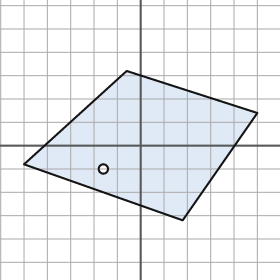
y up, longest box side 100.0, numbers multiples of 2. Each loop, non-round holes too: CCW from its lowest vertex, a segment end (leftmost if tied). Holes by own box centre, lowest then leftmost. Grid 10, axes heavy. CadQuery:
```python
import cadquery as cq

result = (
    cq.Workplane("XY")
    .moveTo(18.0, -32.0)
    .lineTo(50.0, 14.0)
    .lineTo(-6.0, 32.0)
    .lineTo(-50.0, -8.0)
    .close()
    .moveTo(-16.0, -10.0)
    .circle(2.0)
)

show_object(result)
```